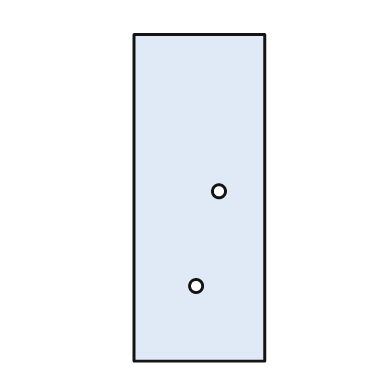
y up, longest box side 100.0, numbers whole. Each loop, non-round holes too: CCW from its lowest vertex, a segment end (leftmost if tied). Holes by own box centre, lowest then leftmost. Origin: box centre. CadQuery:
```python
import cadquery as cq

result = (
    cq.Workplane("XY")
    .moveTo(-20.0, -50.0)
    .lineTo(20.0, -50.0)
    .lineTo(20.0, 50.0)
    .lineTo(-20.0, 50.0)
    .close()
    .moveTo(-1.0, -27.0)
    .circle(2.0)
    .moveTo(6.0, 2.0)
    .circle(2.0)
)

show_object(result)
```